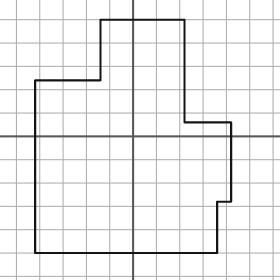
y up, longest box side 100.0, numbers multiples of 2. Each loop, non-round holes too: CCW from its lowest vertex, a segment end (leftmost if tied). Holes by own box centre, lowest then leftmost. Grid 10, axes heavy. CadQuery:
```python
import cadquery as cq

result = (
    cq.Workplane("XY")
    .moveTo(-42.0, -50.0)
    .lineTo(36.0, -50.0)
    .lineTo(36.0, -28.0)
    .lineTo(42.0, -28.0)
    .lineTo(42.0, 6.0)
    .lineTo(22.0, 6.0)
    .lineTo(22.0, 50.0)
    .lineTo(-14.0, 50.0)
    .lineTo(-14.0, 24.0)
    .lineTo(-42.0, 24.0)
    .close()
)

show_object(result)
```